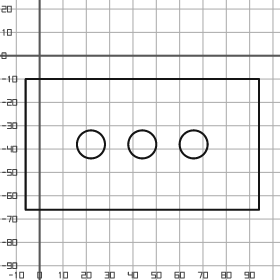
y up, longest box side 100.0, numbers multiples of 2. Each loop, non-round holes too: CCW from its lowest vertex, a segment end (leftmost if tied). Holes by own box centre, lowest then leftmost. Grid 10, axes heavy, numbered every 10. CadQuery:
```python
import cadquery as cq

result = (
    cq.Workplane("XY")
    .moveTo(-6.0, -66.0)
    .lineTo(94.0, -66.0)
    .lineTo(94.0, -10.0)
    .lineTo(-6.0, -10.0)
    .close()
    .moveTo(22.0, -38.0)
    .circle(6.0)
    .moveTo(44.0, -38.0)
    .circle(6.0)
    .moveTo(66.0, -38.0)
    .circle(6.0)
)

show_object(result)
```